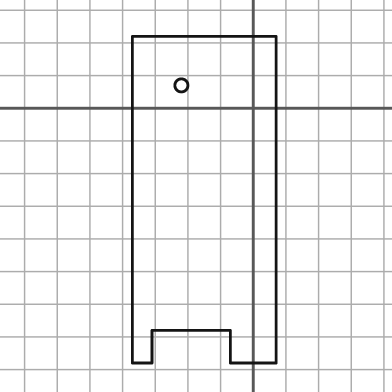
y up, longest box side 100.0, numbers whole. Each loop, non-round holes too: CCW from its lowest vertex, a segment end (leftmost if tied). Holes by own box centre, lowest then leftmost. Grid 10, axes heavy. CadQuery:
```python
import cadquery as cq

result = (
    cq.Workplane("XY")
    .moveTo(-37.0, -78.0)
    .lineTo(-31.0, -78.0)
    .lineTo(-31.0, -68.0)
    .lineTo(-7.0, -68.0)
    .lineTo(-7.0, -78.0)
    .lineTo(7.0, -78.0)
    .lineTo(7.0, 22.0)
    .lineTo(-37.0, 22.0)
    .close()
    .moveTo(-22.0, 7.0)
    .circle(2.0)
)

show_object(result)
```